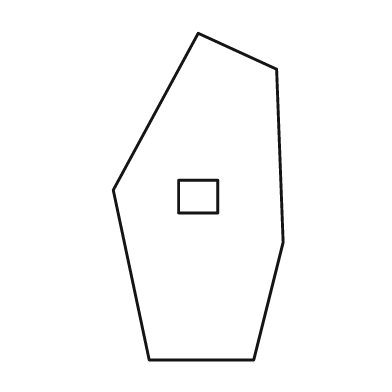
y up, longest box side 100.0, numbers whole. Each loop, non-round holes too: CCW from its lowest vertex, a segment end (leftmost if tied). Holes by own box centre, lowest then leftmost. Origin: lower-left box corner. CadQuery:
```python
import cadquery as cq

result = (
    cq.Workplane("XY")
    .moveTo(11.0, 0.0)
    .lineTo(43.0, 0.0)
    .lineTo(52.0, 36.0)
    .lineTo(50.0, 89.0)
    .lineTo(26.0, 100.0)
    .lineTo(0.0, 52.0)
    .close()
    .moveTo(20.0, 45.0)
    .lineTo(32.0, 45.0)
    .lineTo(32.0, 55.0)
    .lineTo(20.0, 55.0)
    .close()
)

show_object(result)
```